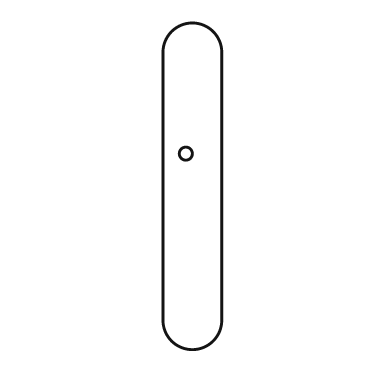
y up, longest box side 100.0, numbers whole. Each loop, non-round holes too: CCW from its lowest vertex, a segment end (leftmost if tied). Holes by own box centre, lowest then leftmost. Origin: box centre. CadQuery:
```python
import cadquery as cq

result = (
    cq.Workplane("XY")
    .moveTo(-9.0, -41.0)
    .threePointArc((0.0, -50.0), (9.0, -41.0))
    .lineTo(9.0, 41.0)
    .threePointArc((0.0, 50.0), (-9.0, 41.0))
    .close()
    .moveTo(-2.0, 10.0)
    .circle(2.0)
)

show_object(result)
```